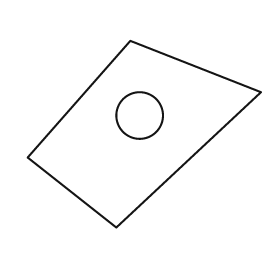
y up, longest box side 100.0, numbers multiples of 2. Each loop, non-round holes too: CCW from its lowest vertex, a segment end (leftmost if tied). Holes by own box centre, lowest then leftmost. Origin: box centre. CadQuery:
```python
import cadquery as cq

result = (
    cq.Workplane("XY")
    .moveTo(-12.0, -40.0)
    .lineTo(50.0, 18.0)
    .lineTo(-6.0, 40.0)
    .lineTo(-50.0, -10.0)
    .close()
    .moveTo(-2.0, 8.0)
    .circle(10.0)
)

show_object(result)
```